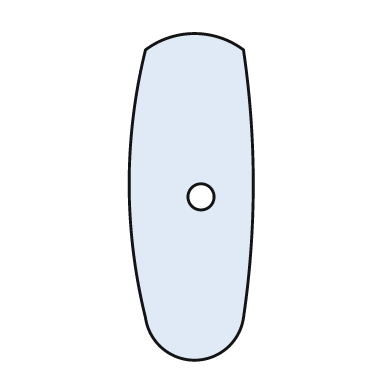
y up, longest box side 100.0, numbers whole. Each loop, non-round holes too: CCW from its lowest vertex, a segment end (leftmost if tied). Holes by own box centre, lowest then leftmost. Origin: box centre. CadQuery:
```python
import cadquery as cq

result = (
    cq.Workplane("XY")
    .moveTo(-14.0, -37.0)
    .threePointArc((1.0, -50.0), (16.0, -37.0))
    .threePointArc((19.0, 4.0), (16.0, 45.0))
    .threePointArc((1.0, 50.0), (-14.0, 45.0))
    .threePointArc((-19.0, 4.0), (-14.0, -37.0))
    .close()
    .moveTo(3.0, 0.0)
    .circle(4.0)
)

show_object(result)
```